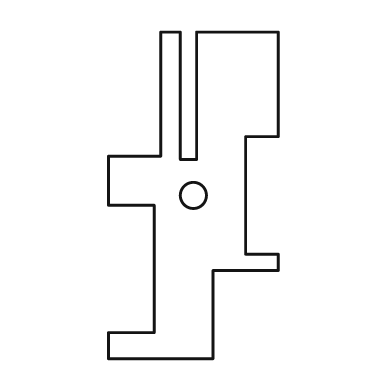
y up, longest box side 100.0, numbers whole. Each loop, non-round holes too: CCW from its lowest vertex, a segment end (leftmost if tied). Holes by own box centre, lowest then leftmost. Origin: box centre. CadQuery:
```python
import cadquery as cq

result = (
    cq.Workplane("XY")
    .moveTo(-26.0, -50.0)
    .lineTo(6.0, -50.0)
    .lineTo(6.0, -23.0)
    .lineTo(26.0, -23.0)
    .lineTo(26.0, -18.0)
    .lineTo(16.0, -18.0)
    .lineTo(16.0, 18.0)
    .lineTo(26.0, 18.0)
    .lineTo(26.0, 50.0)
    .lineTo(1.0, 50.0)
    .lineTo(1.0, 11.0)
    .lineTo(-4.0, 11.0)
    .lineTo(-4.0, 50.0)
    .lineTo(-10.0, 50.0)
    .lineTo(-10.0, 12.0)
    .lineTo(-26.0, 12.0)
    .lineTo(-26.0, -3.0)
    .lineTo(-12.0, -3.0)
    .lineTo(-12.0, -42.0)
    .lineTo(-26.0, -42.0)
    .close()
    .moveTo(0.0, 0.0)
    .circle(4.0)
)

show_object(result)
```